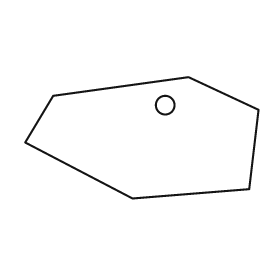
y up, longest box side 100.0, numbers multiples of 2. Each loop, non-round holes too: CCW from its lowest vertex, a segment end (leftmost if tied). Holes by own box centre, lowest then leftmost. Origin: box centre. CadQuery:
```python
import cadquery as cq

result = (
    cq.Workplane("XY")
    .moveTo(-4.0, -26.0)
    .lineTo(46.0, -22.0)
    .lineTo(50.0, 12.0)
    .lineTo(20.0, 26.0)
    .lineTo(-38.0, 18.0)
    .lineTo(-50.0, -2.0)
    .close()
    .moveTo(10.0, 14.0)
    .circle(4.0)
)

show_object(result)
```